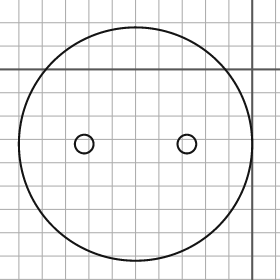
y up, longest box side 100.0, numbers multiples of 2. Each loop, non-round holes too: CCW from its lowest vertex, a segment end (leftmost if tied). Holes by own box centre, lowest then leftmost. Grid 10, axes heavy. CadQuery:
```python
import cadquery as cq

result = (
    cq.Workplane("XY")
    .moveTo(-50.0, -32.0)
    .circle(50.0)
    .moveTo(-72.0, -32.0)
    .circle(4.0)
    .moveTo(-28.0, -32.0)
    .circle(4.0)
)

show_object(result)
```